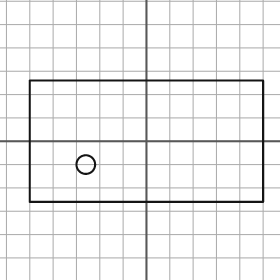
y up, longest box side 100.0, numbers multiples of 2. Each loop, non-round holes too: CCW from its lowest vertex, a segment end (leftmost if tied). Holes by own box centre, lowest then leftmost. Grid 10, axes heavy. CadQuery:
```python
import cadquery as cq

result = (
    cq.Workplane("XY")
    .moveTo(-50.0, -26.0)
    .lineTo(50.0, -26.0)
    .lineTo(50.0, 26.0)
    .lineTo(-50.0, 26.0)
    .close()
    .moveTo(-26.0, -10.0)
    .circle(4.0)
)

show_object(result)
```